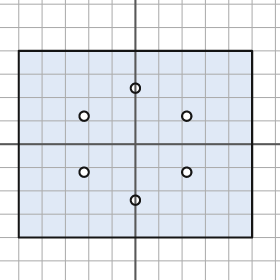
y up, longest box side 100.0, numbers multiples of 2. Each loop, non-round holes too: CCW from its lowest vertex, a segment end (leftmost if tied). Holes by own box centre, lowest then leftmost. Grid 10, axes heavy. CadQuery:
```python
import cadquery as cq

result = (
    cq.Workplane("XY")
    .moveTo(-50.0, -40.0)
    .lineTo(50.0, -40.0)
    .lineTo(50.0, 40.0)
    .lineTo(-50.0, 40.0)
    .close()
    .moveTo(0.0, -24.0)
    .circle(2.0)
    .moveTo(-22.0, -12.0)
    .circle(2.0)
    .moveTo(22.0, -12.0)
    .circle(2.0)
    .moveTo(-22.0, 12.0)
    .circle(2.0)
    .moveTo(22.0, 12.0)
    .circle(2.0)
    .moveTo(0.0, 24.0)
    .circle(2.0)
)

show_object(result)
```